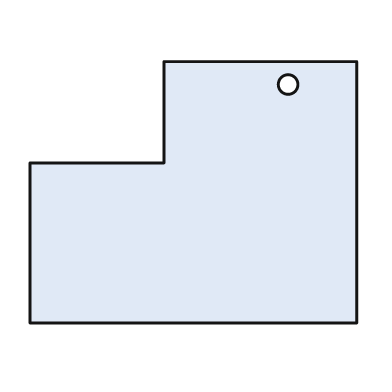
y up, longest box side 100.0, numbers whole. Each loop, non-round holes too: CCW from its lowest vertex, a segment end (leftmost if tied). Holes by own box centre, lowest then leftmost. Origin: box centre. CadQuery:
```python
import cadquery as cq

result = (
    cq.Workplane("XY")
    .moveTo(-50.0, -40.0)
    .lineTo(50.0, -40.0)
    .lineTo(50.0, 40.0)
    .lineTo(-9.0, 40.0)
    .lineTo(-9.0, 9.0)
    .lineTo(-50.0, 9.0)
    .close()
    .moveTo(29.0, 33.0)
    .circle(3.0)
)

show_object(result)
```